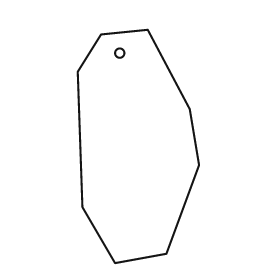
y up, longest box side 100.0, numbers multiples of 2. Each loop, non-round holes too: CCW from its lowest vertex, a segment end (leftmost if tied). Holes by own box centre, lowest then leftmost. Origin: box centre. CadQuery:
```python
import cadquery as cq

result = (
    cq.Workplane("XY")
    .moveTo(-10.0, -50.0)
    .lineTo(12.0, -46.0)
    .lineTo(26.0, -8.0)
    .lineTo(22.0, 16.0)
    .lineTo(4.0, 50.0)
    .lineTo(-16.0, 48.0)
    .lineTo(-26.0, 32.0)
    .lineTo(-24.0, -26.0)
    .close()
    .moveTo(-8.0, 40.0)
    .circle(2.0)
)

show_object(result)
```